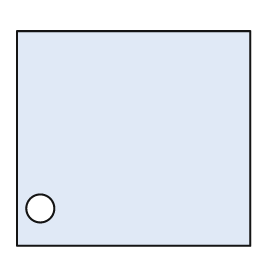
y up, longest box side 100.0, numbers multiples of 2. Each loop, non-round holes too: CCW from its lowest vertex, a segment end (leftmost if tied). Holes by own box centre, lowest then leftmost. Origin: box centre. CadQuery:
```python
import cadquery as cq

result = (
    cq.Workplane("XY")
    .moveTo(-50.0, -46.0)
    .lineTo(50.0, -46.0)
    .lineTo(50.0, 46.0)
    .lineTo(-50.0, 46.0)
    .close()
    .moveTo(-40.0, -30.0)
    .circle(6.0)
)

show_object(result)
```